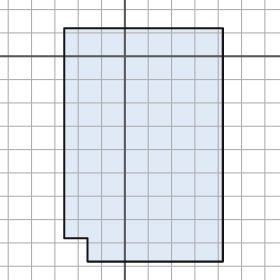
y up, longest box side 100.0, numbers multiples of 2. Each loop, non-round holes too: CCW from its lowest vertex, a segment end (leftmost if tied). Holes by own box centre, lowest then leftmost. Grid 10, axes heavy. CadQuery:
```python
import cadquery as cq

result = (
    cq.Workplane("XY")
    .moveTo(-16.0, -88.0)
    .lineTo(42.0, -88.0)
    .lineTo(42.0, 12.0)
    .lineTo(-26.0, 12.0)
    .lineTo(-26.0, -78.0)
    .lineTo(-16.0, -78.0)
    .close()
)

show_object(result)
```